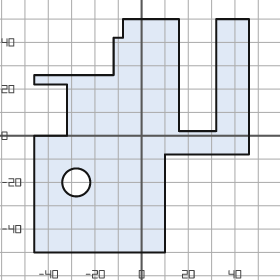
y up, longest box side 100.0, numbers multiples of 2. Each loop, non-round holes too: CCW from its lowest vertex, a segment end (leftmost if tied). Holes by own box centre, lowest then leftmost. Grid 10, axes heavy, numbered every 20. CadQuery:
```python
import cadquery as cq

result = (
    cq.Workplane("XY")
    .moveTo(-46.0, -50.0)
    .lineTo(10.0, -50.0)
    .lineTo(10.0, -8.0)
    .lineTo(46.0, -8.0)
    .lineTo(46.0, 50.0)
    .lineTo(32.0, 50.0)
    .lineTo(32.0, 2.0)
    .lineTo(16.0, 2.0)
    .lineTo(16.0, 50.0)
    .lineTo(-8.0, 50.0)
    .lineTo(-8.0, 42.0)
    .lineTo(-12.0, 42.0)
    .lineTo(-12.0, 26.0)
    .lineTo(-46.0, 26.0)
    .lineTo(-46.0, 22.0)
    .lineTo(-32.0, 22.0)
    .lineTo(-32.0, 0.0)
    .lineTo(-46.0, 0.0)
    .close()
    .moveTo(-28.0, -20.0)
    .circle(6.0)
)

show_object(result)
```